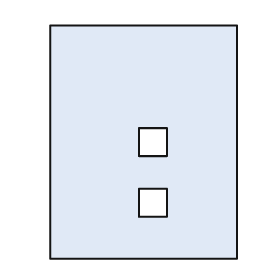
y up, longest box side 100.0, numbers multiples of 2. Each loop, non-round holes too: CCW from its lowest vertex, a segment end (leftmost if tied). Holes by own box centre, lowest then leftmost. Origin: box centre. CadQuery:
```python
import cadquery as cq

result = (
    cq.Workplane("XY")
    .moveTo(-40.0, -50.0)
    .lineTo(40.0, -50.0)
    .lineTo(40.0, 50.0)
    .lineTo(-40.0, 50.0)
    .close()
    .moveTo(-2.0, -32.0)
    .lineTo(10.0, -32.0)
    .lineTo(10.0, -20.0)
    .lineTo(-2.0, -20.0)
    .close()
    .moveTo(-2.0, -6.0)
    .lineTo(10.0, -6.0)
    .lineTo(10.0, 6.0)
    .lineTo(-2.0, 6.0)
    .close()
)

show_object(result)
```